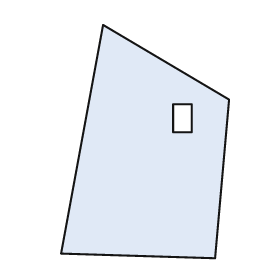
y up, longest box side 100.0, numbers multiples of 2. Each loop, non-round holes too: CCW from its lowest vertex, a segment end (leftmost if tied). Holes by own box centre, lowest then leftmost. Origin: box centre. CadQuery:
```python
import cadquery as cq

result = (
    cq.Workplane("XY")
    .moveTo(30.0, -50.0)
    .lineTo(36.0, 18.0)
    .lineTo(-18.0, 50.0)
    .lineTo(-36.0, -48.0)
    .close()
    .moveTo(12.0, 4.0)
    .lineTo(20.0, 4.0)
    .lineTo(20.0, 16.0)
    .lineTo(12.0, 16.0)
    .close()
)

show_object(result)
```